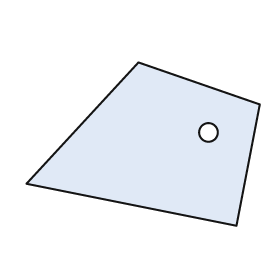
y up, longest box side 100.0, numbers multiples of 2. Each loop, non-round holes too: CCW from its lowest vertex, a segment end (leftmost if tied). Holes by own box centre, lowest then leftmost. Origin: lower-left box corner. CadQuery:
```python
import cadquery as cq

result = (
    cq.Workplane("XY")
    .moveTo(90.0, 0.0)
    .lineTo(100.0, 52.0)
    .lineTo(48.0, 70.0)
    .lineTo(0.0, 18.0)
    .close()
    .moveTo(78.0, 40.0)
    .circle(4.0)
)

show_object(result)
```